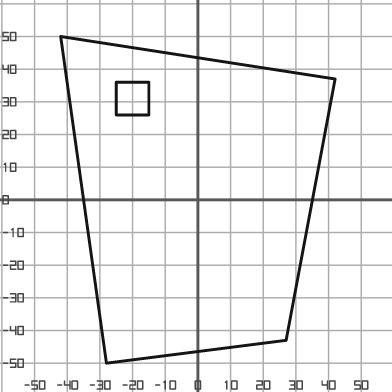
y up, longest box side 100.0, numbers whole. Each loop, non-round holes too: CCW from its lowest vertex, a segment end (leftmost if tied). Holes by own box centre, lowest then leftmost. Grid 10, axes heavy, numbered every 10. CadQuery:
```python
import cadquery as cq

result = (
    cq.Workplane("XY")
    .moveTo(-28.0, -50.0)
    .lineTo(27.0, -43.0)
    .lineTo(42.0, 37.0)
    .lineTo(-42.0, 50.0)
    .close()
    .moveTo(-25.0, 26.0)
    .lineTo(-15.0, 26.0)
    .lineTo(-15.0, 36.0)
    .lineTo(-25.0, 36.0)
    .close()
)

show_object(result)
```